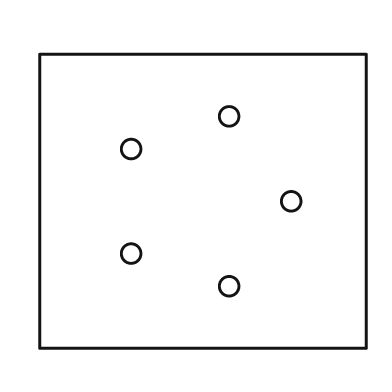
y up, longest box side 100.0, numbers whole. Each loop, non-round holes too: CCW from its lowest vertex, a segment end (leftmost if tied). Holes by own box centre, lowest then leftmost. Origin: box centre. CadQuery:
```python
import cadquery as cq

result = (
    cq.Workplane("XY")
    .moveTo(-50.0, -45.0)
    .lineTo(50.0, -45.0)
    .lineTo(50.0, 45.0)
    .lineTo(-50.0, 45.0)
    .close()
    .moveTo(8.0, -26.0)
    .circle(3.0)
    .moveTo(-22.0, -16.0)
    .circle(3.0)
    .moveTo(27.0, 0.0)
    .circle(3.0)
    .moveTo(-22.0, 16.0)
    .circle(3.0)
    .moveTo(8.0, 26.0)
    .circle(3.0)
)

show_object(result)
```